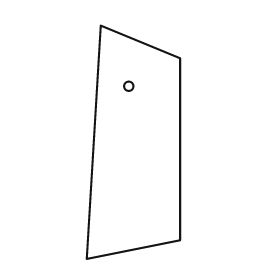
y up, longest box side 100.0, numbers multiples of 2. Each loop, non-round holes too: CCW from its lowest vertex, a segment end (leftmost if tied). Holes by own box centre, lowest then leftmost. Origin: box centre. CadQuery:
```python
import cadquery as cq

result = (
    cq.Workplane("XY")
    .moveTo(-20.0, -50.0)
    .lineTo(20.0, -42.0)
    .lineTo(20.0, 36.0)
    .lineTo(-14.0, 50.0)
    .close()
    .moveTo(-2.0, 24.0)
    .circle(2.0)
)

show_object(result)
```